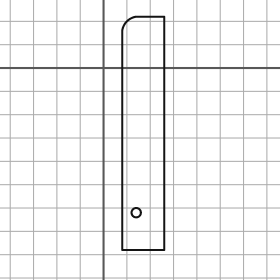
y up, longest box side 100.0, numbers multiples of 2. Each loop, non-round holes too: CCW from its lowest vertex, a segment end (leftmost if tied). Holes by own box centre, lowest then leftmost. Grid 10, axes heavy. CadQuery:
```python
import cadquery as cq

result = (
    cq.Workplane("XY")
    .moveTo(8.0, -78.0)
    .lineTo(26.0, -78.0)
    .lineTo(26.0, 22.0)
    .lineTo(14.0, 22.0)
    .threePointArc((10.0, 20.0), (8.0, 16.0))
    .close()
    .moveTo(14.0, -62.0)
    .circle(2.0)
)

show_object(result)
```